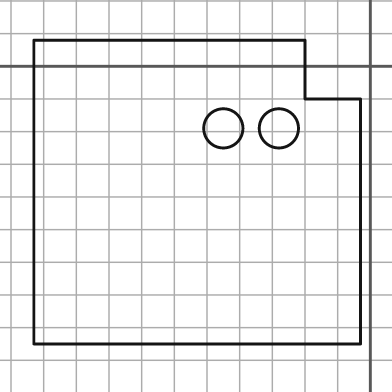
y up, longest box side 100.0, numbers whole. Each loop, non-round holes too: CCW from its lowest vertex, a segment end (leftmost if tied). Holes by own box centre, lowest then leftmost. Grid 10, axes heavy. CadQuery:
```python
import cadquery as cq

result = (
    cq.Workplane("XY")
    .moveTo(-103.0, -85.0)
    .lineTo(-3.0, -85.0)
    .lineTo(-3.0, -10.0)
    .lineTo(-20.0, -10.0)
    .lineTo(-20.0, 8.0)
    .lineTo(-103.0, 8.0)
    .close()
    .moveTo(-45.0, -19.0)
    .circle(6.0)
    .moveTo(-28.0, -19.0)
    .circle(6.0)
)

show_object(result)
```